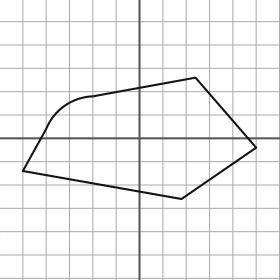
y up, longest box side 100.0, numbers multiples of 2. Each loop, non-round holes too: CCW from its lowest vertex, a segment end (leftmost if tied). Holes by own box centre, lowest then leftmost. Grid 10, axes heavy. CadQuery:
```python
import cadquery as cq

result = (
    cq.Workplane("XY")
    .moveTo(18.0, -26.0)
    .lineTo(50.0, -4.0)
    .lineTo(24.0, 26.0)
    .lineTo(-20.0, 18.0)
    .threePointArc((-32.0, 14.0), (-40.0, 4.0))
    .lineTo(-50.0, -14.0)
    .close()
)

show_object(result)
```